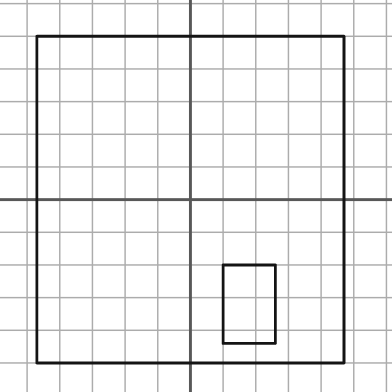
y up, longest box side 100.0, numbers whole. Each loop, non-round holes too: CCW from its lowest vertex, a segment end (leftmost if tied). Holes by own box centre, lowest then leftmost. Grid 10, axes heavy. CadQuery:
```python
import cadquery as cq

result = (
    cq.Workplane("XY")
    .moveTo(-47.0, -50.0)
    .lineTo(47.0, -50.0)
    .lineTo(47.0, 50.0)
    .lineTo(-47.0, 50.0)
    .close()
    .moveTo(10.0, -44.0)
    .lineTo(26.0, -44.0)
    .lineTo(26.0, -20.0)
    .lineTo(10.0, -20.0)
    .close()
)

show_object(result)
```